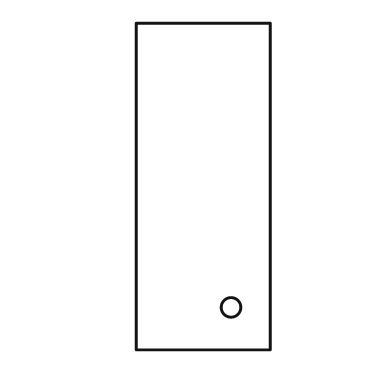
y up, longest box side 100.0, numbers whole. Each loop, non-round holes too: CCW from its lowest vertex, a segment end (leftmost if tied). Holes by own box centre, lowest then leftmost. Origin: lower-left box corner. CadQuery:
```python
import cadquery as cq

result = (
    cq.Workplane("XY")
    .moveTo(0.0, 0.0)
    .lineTo(41.0, 0.0)
    .lineTo(41.0, 100.0)
    .lineTo(0.0, 100.0)
    .close()
    .moveTo(29.0, 13.0)
    .circle(3.0)
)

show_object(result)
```